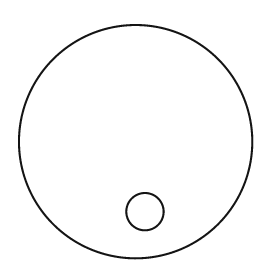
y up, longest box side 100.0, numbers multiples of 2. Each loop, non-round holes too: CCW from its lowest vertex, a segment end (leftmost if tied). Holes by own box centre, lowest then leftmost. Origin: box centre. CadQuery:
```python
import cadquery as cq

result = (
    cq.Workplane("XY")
    .moveTo(0.0, 0.0)
    .circle(50.0)
    .moveTo(4.0, -30.0)
    .circle(8.0)
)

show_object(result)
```